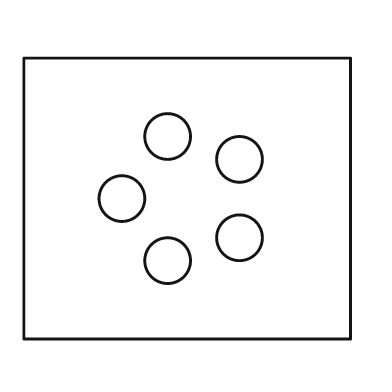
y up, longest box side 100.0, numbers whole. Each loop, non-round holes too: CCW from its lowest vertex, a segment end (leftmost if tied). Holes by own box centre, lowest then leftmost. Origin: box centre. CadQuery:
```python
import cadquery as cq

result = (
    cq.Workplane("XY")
    .moveTo(-50.0, -43.0)
    .lineTo(50.0, -43.0)
    .lineTo(50.0, 43.0)
    .lineTo(-50.0, 43.0)
    .close()
    .moveTo(-6.0, -19.0)
    .circle(7.0)
    .moveTo(16.0, -12.0)
    .circle(7.0)
    .moveTo(-20.0, 0.0)
    .circle(7.0)
    .moveTo(16.0, 12.0)
    .circle(7.0)
    .moveTo(-6.0, 19.0)
    .circle(7.0)
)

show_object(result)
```